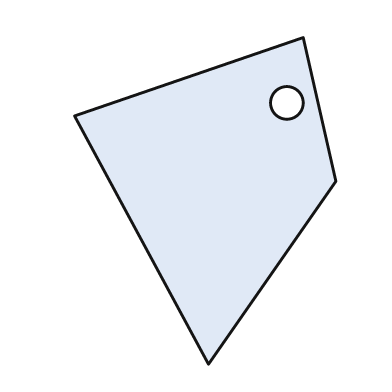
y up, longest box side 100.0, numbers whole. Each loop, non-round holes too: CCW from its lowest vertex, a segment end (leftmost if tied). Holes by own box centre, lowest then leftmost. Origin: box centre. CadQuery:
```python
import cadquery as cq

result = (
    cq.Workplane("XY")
    .moveTo(1.0, -50.0)
    .lineTo(40.0, 6.0)
    .lineTo(30.0, 50.0)
    .lineTo(-40.0, 26.0)
    .close()
    .moveTo(25.0, 30.0)
    .circle(5.0)
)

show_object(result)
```